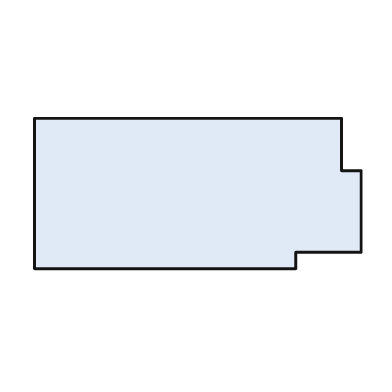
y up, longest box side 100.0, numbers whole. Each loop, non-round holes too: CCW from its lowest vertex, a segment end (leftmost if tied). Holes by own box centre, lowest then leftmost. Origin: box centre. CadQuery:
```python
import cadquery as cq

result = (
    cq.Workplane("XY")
    .moveTo(-50.0, -23.0)
    .lineTo(30.0, -23.0)
    .lineTo(30.0, -18.0)
    .lineTo(50.0, -18.0)
    .lineTo(50.0, 7.0)
    .lineTo(44.0, 7.0)
    .lineTo(44.0, 23.0)
    .lineTo(-50.0, 23.0)
    .close()
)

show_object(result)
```